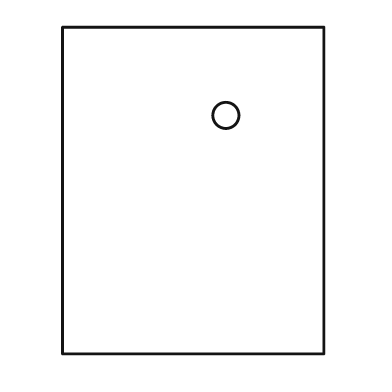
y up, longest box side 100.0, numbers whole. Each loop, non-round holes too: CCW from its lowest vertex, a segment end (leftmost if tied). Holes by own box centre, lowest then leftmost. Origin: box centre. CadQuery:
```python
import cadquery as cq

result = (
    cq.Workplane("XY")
    .moveTo(-40.0, -50.0)
    .lineTo(40.0, -50.0)
    .lineTo(40.0, 50.0)
    .lineTo(-40.0, 50.0)
    .close()
    .moveTo(10.0, 23.0)
    .circle(4.0)
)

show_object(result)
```